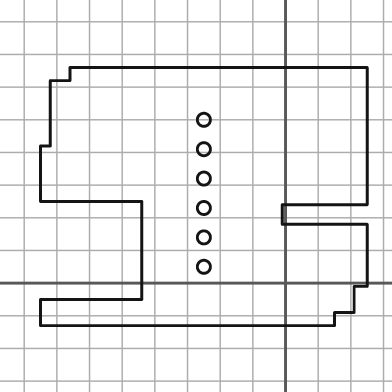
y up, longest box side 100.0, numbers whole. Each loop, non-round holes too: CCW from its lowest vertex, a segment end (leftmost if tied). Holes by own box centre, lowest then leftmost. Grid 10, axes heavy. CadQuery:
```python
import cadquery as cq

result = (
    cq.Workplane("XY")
    .moveTo(-75.0, -13.0)
    .lineTo(15.0, -13.0)
    .lineTo(15.0, -9.0)
    .lineTo(21.0, -9.0)
    .lineTo(21.0, -1.0)
    .lineTo(25.0, -1.0)
    .lineTo(25.0, 18.0)
    .lineTo(-1.0, 18.0)
    .lineTo(-1.0, 24.0)
    .lineTo(25.0, 24.0)
    .lineTo(25.0, 66.0)
    .lineTo(-66.0, 66.0)
    .lineTo(-66.0, 62.0)
    .lineTo(-72.0, 62.0)
    .lineTo(-72.0, 42.0)
    .lineTo(-75.0, 42.0)
    .lineTo(-75.0, 25.0)
    .lineTo(-44.0, 25.0)
    .lineTo(-44.0, -5.0)
    .lineTo(-75.0, -5.0)
    .close()
    .moveTo(-25.0, 5.0)
    .circle(2.0)
    .moveTo(-25.0, 14.0)
    .circle(2.0)
    .moveTo(-25.0, 23.0)
    .circle(2.0)
    .moveTo(-25.0, 32.0)
    .circle(2.0)
    .moveTo(-25.0, 41.0)
    .circle(2.0)
    .moveTo(-25.0, 50.0)
    .circle(2.0)
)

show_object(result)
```